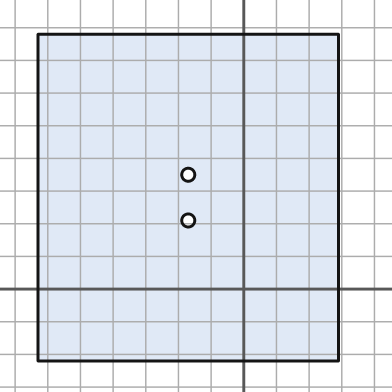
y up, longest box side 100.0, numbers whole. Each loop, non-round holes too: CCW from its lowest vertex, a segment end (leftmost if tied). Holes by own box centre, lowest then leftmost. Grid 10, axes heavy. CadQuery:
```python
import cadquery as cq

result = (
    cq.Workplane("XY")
    .moveTo(-63.0, -22.0)
    .lineTo(29.0, -22.0)
    .lineTo(29.0, 78.0)
    .lineTo(-63.0, 78.0)
    .close()
    .moveTo(-17.0, 21.0)
    .circle(2.0)
    .moveTo(-17.0, 35.0)
    .circle(2.0)
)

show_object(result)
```